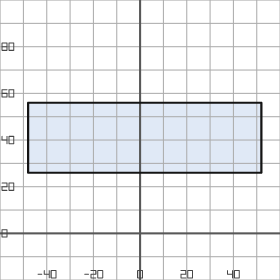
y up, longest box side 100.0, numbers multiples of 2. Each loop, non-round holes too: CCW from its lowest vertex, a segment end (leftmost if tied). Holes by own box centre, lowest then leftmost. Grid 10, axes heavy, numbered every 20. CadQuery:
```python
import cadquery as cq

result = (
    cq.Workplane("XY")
    .moveTo(-48.0, 26.0)
    .lineTo(52.0, 26.0)
    .lineTo(52.0, 56.0)
    .lineTo(-48.0, 56.0)
    .close()
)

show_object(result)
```